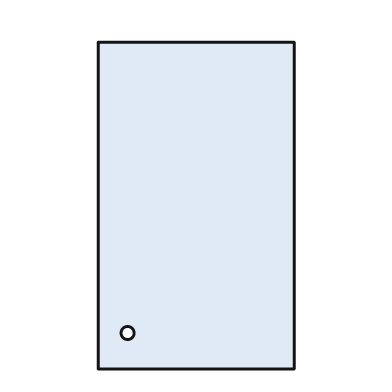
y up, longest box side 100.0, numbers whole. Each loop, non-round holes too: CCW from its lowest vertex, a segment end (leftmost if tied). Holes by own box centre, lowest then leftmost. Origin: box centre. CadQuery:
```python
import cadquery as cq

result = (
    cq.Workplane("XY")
    .moveTo(-30.0, -50.0)
    .lineTo(30.0, -50.0)
    .lineTo(30.0, 50.0)
    .lineTo(-30.0, 50.0)
    .close()
    .moveTo(-21.0, -39.0)
    .circle(2.0)
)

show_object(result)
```